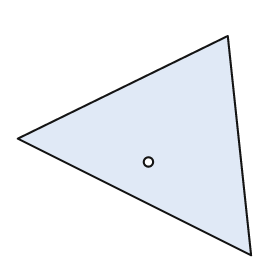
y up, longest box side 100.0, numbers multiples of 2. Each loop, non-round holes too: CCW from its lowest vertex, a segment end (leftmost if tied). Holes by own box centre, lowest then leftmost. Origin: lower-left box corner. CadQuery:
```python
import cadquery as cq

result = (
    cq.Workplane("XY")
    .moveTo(100.0, 0.0)
    .lineTo(90.0, 94.0)
    .lineTo(0.0, 50.0)
    .close()
    .moveTo(56.0, 40.0)
    .circle(2.0)
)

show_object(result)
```